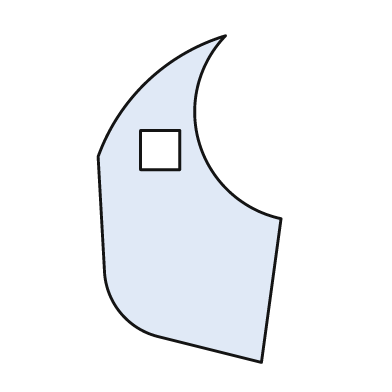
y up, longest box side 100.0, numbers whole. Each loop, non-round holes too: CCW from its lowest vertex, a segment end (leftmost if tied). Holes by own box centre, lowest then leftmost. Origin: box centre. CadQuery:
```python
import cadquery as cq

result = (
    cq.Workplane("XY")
    .moveTo(22.0, -50.0)
    .lineTo(28.0, -6.0)
    .threePointArc((3.0, 17.0), (11.0, 50.0))
    .threePointArc((-13.0, 36.0), (-28.0, 13.0))
    .lineTo(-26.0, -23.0)
    .threePointArc((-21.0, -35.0), (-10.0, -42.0))
    .close()
    .moveTo(-15.0, 9.0)
    .lineTo(-3.0, 9.0)
    .lineTo(-3.0, 21.0)
    .lineTo(-15.0, 21.0)
    .close()
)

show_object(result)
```